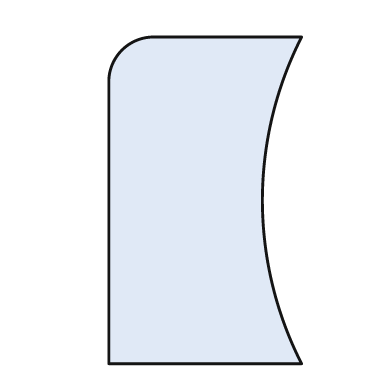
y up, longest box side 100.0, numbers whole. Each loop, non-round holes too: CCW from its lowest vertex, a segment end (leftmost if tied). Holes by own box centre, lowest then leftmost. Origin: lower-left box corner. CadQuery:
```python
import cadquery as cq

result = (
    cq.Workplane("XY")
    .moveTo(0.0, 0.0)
    .lineTo(59.0, 0.0)
    .threePointArc((47.0, 50.0), (59.0, 100.0))
    .lineTo(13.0, 100.0)
    .threePointArc((4.0, 96.0), (0.0, 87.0))
    .close()
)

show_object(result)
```